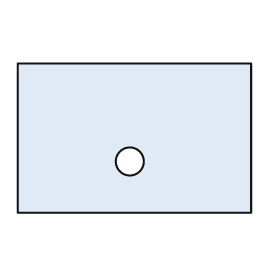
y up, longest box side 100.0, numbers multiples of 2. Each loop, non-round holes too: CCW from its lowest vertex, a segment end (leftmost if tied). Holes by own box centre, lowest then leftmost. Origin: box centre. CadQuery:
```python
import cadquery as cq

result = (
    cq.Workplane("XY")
    .moveTo(-50.0, -32.0)
    .lineTo(50.0, -32.0)
    .lineTo(50.0, 32.0)
    .lineTo(-50.0, 32.0)
    .close()
    .moveTo(-2.0, -10.0)
    .circle(6.0)
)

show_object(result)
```